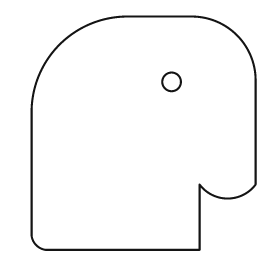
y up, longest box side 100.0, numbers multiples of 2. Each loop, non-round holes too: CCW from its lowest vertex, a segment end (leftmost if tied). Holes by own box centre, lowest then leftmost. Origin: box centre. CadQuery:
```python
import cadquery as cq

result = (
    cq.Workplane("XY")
    .moveTo(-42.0, -50.0)
    .lineTo(24.0, -50.0)
    .lineTo(24.0, -22.0)
    .threePointArc((36.0, -28.0), (48.0, -22.0))
    .lineTo(48.0, 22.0)
    .threePointArc((40.0, 42.0), (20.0, 50.0))
    .lineTo(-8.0, 50.0)
    .threePointArc((-36.0, 38.0), (-48.0, 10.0))
    .lineTo(-48.0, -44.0)
    .threePointArc((-46.0, -48.0), (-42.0, -50.0))
    .close()
    .moveTo(12.0, 22.0)
    .circle(4.0)
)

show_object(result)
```